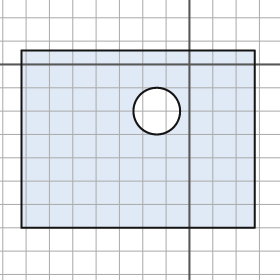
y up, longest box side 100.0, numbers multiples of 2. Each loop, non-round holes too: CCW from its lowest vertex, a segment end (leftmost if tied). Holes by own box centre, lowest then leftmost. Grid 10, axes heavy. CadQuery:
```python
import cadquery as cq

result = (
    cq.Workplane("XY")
    .moveTo(-72.0, -70.0)
    .lineTo(28.0, -70.0)
    .lineTo(28.0, 6.0)
    .lineTo(-72.0, 6.0)
    .close()
    .moveTo(-14.0, -20.0)
    .circle(10.0)
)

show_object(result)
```